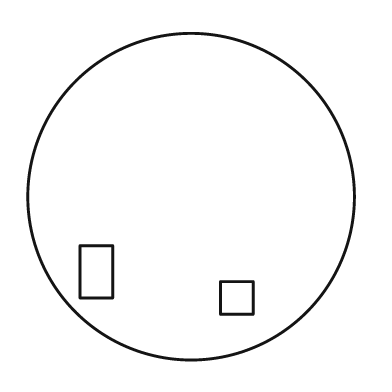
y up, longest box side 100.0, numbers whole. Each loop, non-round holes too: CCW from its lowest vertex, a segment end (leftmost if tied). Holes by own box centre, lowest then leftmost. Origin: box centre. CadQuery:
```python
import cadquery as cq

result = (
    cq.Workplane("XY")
    .moveTo(0.0, 0.0)
    .circle(50.0)
    .moveTo(9.0, -36.0)
    .lineTo(19.0, -36.0)
    .lineTo(19.0, -26.0)
    .lineTo(9.0, -26.0)
    .close()
    .moveTo(-34.0, -31.0)
    .lineTo(-24.0, -31.0)
    .lineTo(-24.0, -15.0)
    .lineTo(-34.0, -15.0)
    .close()
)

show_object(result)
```